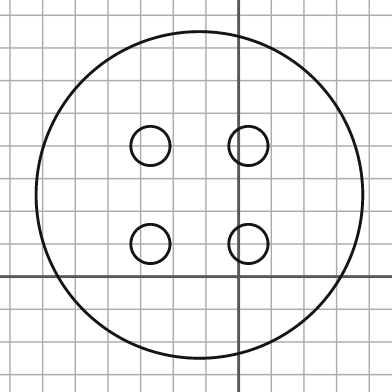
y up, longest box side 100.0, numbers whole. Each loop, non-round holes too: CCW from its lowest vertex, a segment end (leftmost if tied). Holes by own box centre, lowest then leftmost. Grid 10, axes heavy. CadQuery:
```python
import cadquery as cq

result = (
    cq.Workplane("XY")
    .moveTo(-12.0, 25.0)
    .circle(50.0)
    .moveTo(-27.0, 10.0)
    .circle(6.0)
    .moveTo(3.0, 10.0)
    .circle(6.0)
    .moveTo(-27.0, 40.0)
    .circle(6.0)
    .moveTo(3.0, 40.0)
    .circle(6.0)
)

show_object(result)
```